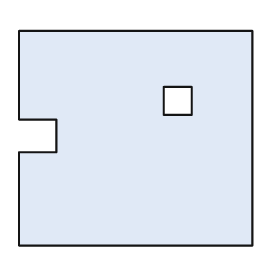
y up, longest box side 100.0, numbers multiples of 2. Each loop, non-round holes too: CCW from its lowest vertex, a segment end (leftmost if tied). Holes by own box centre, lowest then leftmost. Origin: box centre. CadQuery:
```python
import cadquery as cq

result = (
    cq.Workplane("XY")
    .moveTo(-50.0, -46.0)
    .lineTo(50.0, -46.0)
    .lineTo(50.0, 46.0)
    .lineTo(-50.0, 46.0)
    .lineTo(-50.0, 8.0)
    .lineTo(-34.0, 8.0)
    .lineTo(-34.0, -6.0)
    .lineTo(-50.0, -6.0)
    .close()
    .moveTo(12.0, 10.0)
    .lineTo(24.0, 10.0)
    .lineTo(24.0, 22.0)
    .lineTo(12.0, 22.0)
    .close()
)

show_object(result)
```